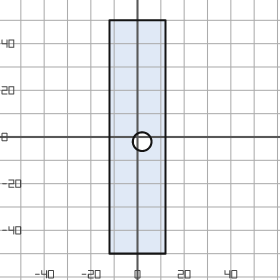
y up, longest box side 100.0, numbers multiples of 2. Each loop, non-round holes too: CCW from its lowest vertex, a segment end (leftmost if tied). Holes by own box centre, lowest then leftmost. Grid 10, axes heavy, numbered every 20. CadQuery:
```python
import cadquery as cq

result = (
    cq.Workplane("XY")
    .moveTo(-12.0, -50.0)
    .lineTo(12.0, -50.0)
    .lineTo(12.0, 50.0)
    .lineTo(-12.0, 50.0)
    .close()
    .moveTo(2.0, -2.0)
    .circle(4.0)
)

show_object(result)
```